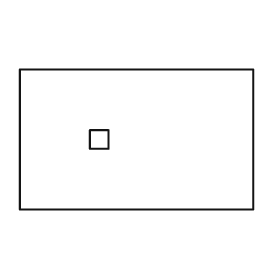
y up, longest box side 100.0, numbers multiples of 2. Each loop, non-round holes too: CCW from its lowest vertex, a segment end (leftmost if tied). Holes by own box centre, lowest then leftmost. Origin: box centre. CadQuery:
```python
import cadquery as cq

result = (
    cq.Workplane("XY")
    .moveTo(-50.0, -30.0)
    .lineTo(50.0, -30.0)
    .lineTo(50.0, 30.0)
    .lineTo(-50.0, 30.0)
    .close()
    .moveTo(-20.0, -4.0)
    .lineTo(-12.0, -4.0)
    .lineTo(-12.0, 4.0)
    .lineTo(-20.0, 4.0)
    .close()
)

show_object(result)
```